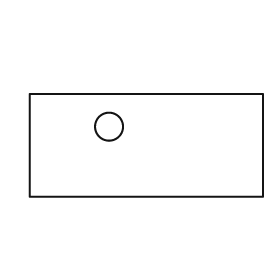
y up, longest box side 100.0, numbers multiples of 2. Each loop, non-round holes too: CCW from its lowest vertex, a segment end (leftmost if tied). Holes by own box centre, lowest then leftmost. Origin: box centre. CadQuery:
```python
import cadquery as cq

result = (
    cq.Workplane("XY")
    .moveTo(-50.0, -22.0)
    .lineTo(50.0, -22.0)
    .lineTo(50.0, 22.0)
    .lineTo(-50.0, 22.0)
    .close()
    .moveTo(-16.0, 8.0)
    .circle(6.0)
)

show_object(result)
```